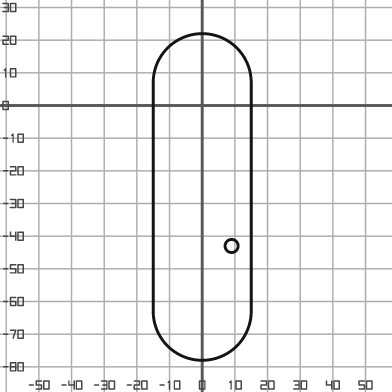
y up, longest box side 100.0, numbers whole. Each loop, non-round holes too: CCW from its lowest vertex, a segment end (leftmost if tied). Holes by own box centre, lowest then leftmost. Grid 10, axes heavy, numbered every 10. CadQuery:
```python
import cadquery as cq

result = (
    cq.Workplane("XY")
    .moveTo(-15.0, -63.0)
    .threePointArc((0.0, -78.0), (15.0, -63.0))
    .lineTo(15.0, 7.0)
    .threePointArc((0.0, 22.0), (-15.0, 7.0))
    .close()
    .moveTo(9.0, -43.0)
    .circle(2.0)
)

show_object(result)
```